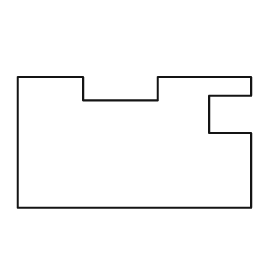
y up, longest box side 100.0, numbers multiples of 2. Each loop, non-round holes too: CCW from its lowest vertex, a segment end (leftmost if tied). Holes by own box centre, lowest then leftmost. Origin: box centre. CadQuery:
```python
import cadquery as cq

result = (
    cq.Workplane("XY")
    .moveTo(-50.0, -28.0)
    .lineTo(50.0, -28.0)
    .lineTo(50.0, 4.0)
    .lineTo(32.0, 4.0)
    .lineTo(32.0, 20.0)
    .lineTo(50.0, 20.0)
    .lineTo(50.0, 28.0)
    .lineTo(10.0, 28.0)
    .lineTo(10.0, 18.0)
    .lineTo(-22.0, 18.0)
    .lineTo(-22.0, 28.0)
    .lineTo(-50.0, 28.0)
    .close()
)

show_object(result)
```